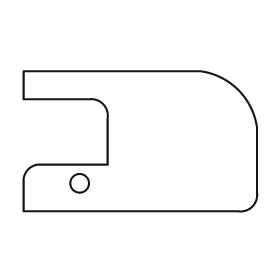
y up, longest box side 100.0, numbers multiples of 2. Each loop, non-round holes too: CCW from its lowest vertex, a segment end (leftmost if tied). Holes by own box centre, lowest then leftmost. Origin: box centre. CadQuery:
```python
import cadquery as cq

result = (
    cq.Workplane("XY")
    .moveTo(-50.0, -30.0)
    .lineTo(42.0, -30.0)
    .threePointArc((48.0, -28.0), (50.0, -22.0))
    .lineTo(50.0, 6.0)
    .threePointArc((42.0, 22.0), (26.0, 30.0))
    .lineTo(-50.0, 30.0)
    .lineTo(-50.0, 18.0)
    .lineTo(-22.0, 18.0)
    .threePointArc((-16.0, 16.0), (-14.0, 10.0))
    .lineTo(-14.0, -10.0)
    .lineTo(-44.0, -10.0)
    .threePointArc((-48.0, -12.0), (-50.0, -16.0))
    .close()
    .moveTo(-26.0, -18.0)
    .circle(4.0)
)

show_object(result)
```